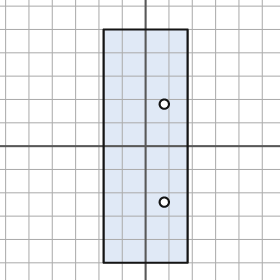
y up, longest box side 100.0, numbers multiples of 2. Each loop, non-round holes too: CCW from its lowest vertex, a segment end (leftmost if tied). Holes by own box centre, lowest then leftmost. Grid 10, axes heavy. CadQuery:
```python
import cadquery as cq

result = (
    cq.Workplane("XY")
    .moveTo(-18.0, -50.0)
    .lineTo(18.0, -50.0)
    .lineTo(18.0, 50.0)
    .lineTo(-18.0, 50.0)
    .close()
    .moveTo(8.0, -24.0)
    .circle(2.0)
    .moveTo(8.0, 18.0)
    .circle(2.0)
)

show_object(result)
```